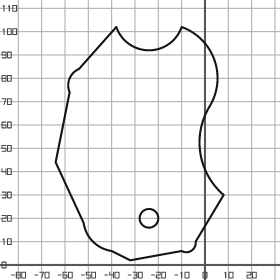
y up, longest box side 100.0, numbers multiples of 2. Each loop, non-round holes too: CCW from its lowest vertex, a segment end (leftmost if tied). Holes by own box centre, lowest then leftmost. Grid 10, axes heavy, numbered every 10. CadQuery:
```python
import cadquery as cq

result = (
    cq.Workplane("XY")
    .moveTo(-32.0, 2.0)
    .lineTo(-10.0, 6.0)
    .threePointArc((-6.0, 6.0), (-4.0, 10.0))
    .lineTo(8.0, 30.0)
    .threePointArc((-2.0, 48.0), (2.0, 68.0))
    .threePointArc((4.0, 88.0), (-10.0, 102.0))
    .threePointArc((-24.0, 92.0), (-38.0, 102.0))
    .lineTo(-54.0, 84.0)
    .threePointArc((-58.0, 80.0), (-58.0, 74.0))
    .lineTo(-64.0, 44.0)
    .lineTo(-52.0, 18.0)
    .threePointArc((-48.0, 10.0), (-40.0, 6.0))
    .close()
    .moveTo(-24.0, 20.0)
    .circle(4.0)
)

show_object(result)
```